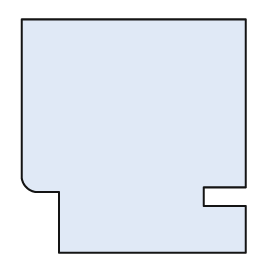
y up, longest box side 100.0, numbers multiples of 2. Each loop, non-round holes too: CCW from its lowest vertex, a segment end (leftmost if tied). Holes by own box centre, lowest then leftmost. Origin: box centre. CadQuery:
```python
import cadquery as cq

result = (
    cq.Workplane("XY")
    .moveTo(-32.0, -50.0)
    .lineTo(48.0, -50.0)
    .lineTo(48.0, -30.0)
    .lineTo(30.0, -30.0)
    .lineTo(30.0, -22.0)
    .lineTo(48.0, -22.0)
    .lineTo(48.0, 50.0)
    .lineTo(-48.0, 50.0)
    .lineTo(-48.0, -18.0)
    .threePointArc((-46.0, -22.0), (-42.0, -24.0))
    .lineTo(-32.0, -24.0)
    .close()
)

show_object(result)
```